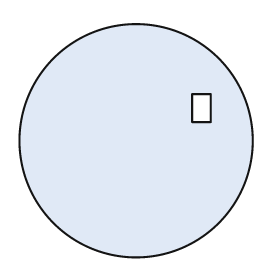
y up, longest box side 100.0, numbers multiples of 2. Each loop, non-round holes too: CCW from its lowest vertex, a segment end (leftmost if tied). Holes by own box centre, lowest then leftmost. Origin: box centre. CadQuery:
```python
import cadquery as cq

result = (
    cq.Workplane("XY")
    .moveTo(0.0, 0.0)
    .circle(50.0)
    .moveTo(24.0, 8.0)
    .lineTo(32.0, 8.0)
    .lineTo(32.0, 20.0)
    .lineTo(24.0, 20.0)
    .close()
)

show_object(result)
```